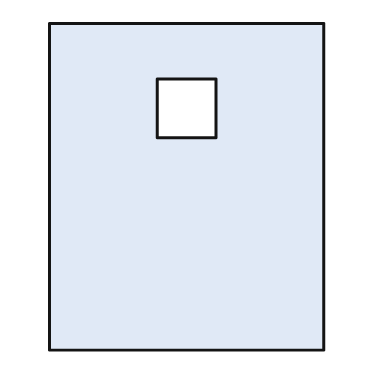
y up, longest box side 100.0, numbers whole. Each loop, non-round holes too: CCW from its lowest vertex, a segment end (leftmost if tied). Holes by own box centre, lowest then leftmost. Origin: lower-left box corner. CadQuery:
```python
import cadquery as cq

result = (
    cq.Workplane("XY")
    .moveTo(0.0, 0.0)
    .lineTo(84.0, 0.0)
    .lineTo(84.0, 100.0)
    .lineTo(0.0, 100.0)
    .close()
    .moveTo(33.0, 65.0)
    .lineTo(51.0, 65.0)
    .lineTo(51.0, 83.0)
    .lineTo(33.0, 83.0)
    .close()
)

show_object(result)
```